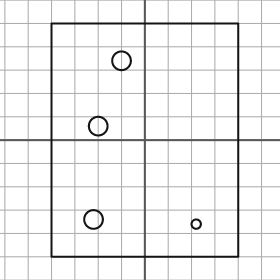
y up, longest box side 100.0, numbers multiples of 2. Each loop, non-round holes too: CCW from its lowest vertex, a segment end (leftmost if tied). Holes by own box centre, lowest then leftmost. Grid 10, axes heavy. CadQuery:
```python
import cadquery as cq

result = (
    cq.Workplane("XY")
    .moveTo(-40.0, -50.0)
    .lineTo(40.0, -50.0)
    .lineTo(40.0, 50.0)
    .lineTo(-40.0, 50.0)
    .close()
    .moveTo(22.0, -36.0)
    .circle(2.0)
    .moveTo(-22.0, -34.0)
    .circle(4.0)
    .moveTo(-20.0, 6.0)
    .circle(4.0)
    .moveTo(-10.0, 34.0)
    .circle(4.0)
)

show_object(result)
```